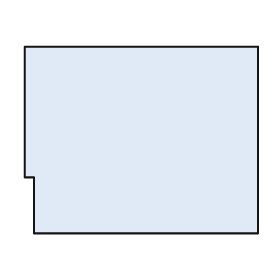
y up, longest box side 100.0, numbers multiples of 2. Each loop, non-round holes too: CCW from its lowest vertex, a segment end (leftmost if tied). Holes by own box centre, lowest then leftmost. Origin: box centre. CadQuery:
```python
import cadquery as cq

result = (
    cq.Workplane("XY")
    .moveTo(-46.0, -40.0)
    .lineTo(50.0, -40.0)
    .lineTo(50.0, 40.0)
    .lineTo(-50.0, 40.0)
    .lineTo(-50.0, -16.0)
    .lineTo(-46.0, -16.0)
    .close()
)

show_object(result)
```